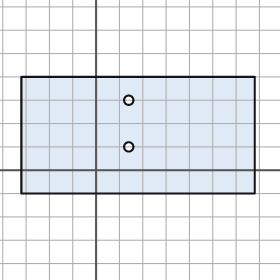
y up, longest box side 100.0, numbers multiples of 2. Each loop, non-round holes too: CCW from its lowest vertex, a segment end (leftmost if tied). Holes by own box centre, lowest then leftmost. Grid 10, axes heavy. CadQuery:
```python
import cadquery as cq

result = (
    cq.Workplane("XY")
    .moveTo(-32.0, -10.0)
    .lineTo(68.0, -10.0)
    .lineTo(68.0, 40.0)
    .lineTo(-32.0, 40.0)
    .close()
    .moveTo(14.0, 10.0)
    .circle(2.0)
    .moveTo(14.0, 30.0)
    .circle(2.0)
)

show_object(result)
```